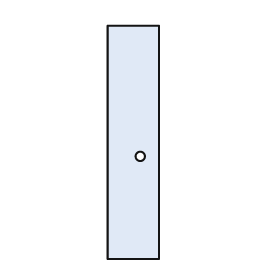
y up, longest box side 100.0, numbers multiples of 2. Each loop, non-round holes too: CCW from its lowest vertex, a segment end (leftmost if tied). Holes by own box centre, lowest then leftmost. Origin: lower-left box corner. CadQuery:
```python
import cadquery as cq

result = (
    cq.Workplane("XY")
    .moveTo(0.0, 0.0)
    .lineTo(22.0, 0.0)
    .lineTo(22.0, 100.0)
    .lineTo(0.0, 100.0)
    .close()
    .moveTo(14.0, 44.0)
    .circle(2.0)
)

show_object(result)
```